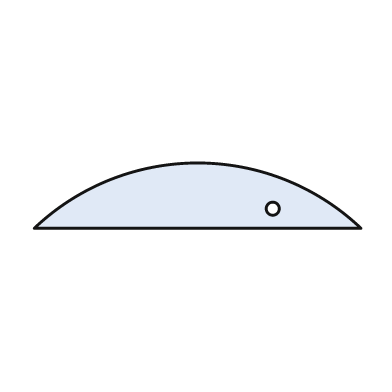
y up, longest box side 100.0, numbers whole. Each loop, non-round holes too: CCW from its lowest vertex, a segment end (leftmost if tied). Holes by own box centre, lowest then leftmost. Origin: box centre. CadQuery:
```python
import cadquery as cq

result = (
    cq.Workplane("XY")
    .moveTo(-50.0, -10.0)
    .lineTo(50.0, -10.0)
    .threePointArc((0.0, 10.0), (-50.0, -10.0))
    .close()
    .moveTo(23.0, -4.0)
    .circle(2.0)
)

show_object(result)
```